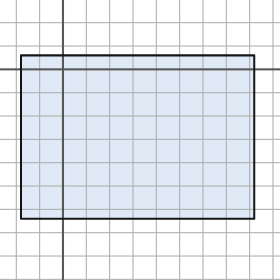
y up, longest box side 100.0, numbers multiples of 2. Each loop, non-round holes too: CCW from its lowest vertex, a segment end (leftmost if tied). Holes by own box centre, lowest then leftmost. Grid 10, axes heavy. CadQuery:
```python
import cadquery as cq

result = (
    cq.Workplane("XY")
    .moveTo(-18.0, -64.0)
    .lineTo(82.0, -64.0)
    .lineTo(82.0, 6.0)
    .lineTo(-18.0, 6.0)
    .close()
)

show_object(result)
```